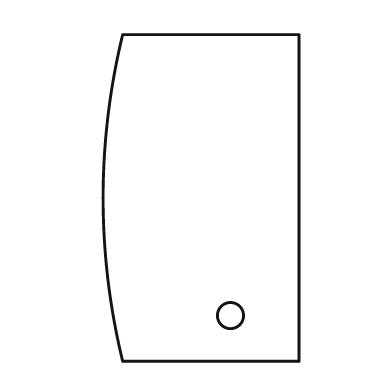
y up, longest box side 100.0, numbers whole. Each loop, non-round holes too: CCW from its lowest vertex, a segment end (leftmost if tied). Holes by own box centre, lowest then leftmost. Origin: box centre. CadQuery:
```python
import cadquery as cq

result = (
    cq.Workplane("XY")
    .moveTo(-24.0, -50.0)
    .lineTo(30.0, -50.0)
    .lineTo(30.0, 50.0)
    .lineTo(-24.0, 50.0)
    .threePointArc((-30.0, 0.0), (-24.0, -50.0))
    .close()
    .moveTo(9.0, -36.0)
    .circle(4.0)
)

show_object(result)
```